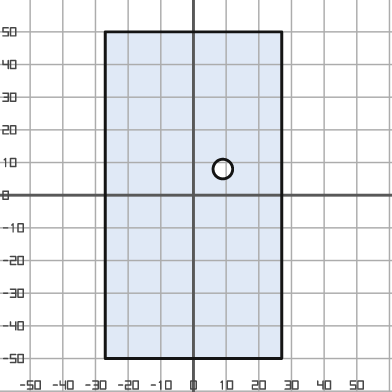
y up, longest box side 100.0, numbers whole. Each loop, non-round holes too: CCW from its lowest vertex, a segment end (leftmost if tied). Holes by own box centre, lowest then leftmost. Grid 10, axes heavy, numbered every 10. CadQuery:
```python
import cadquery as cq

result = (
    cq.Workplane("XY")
    .moveTo(-27.0, -50.0)
    .lineTo(27.0, -50.0)
    .lineTo(27.0, 50.0)
    .lineTo(-27.0, 50.0)
    .close()
    .moveTo(9.0, 8.0)
    .circle(3.0)
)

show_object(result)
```